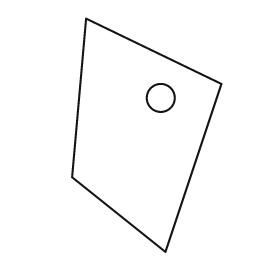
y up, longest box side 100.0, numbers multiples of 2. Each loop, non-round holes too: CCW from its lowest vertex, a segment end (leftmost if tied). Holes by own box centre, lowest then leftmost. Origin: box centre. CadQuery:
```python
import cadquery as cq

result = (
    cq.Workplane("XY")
    .moveTo(8.0, -50.0)
    .lineTo(32.0, 22.0)
    .lineTo(-26.0, 50.0)
    .lineTo(-32.0, -18.0)
    .close()
    .moveTo(6.0, 16.0)
    .circle(6.0)
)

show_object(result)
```